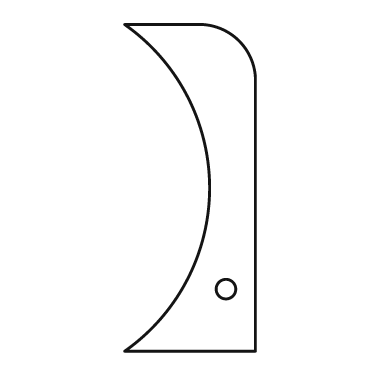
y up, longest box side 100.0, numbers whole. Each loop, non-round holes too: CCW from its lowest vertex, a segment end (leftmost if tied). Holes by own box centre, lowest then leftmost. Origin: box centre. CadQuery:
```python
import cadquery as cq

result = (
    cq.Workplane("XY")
    .moveTo(-20.0, -50.0)
    .lineTo(20.0, -50.0)
    .lineTo(20.0, 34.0)
    .threePointArc((15.0, 45.0), (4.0, 50.0))
    .lineTo(-20.0, 50.0)
    .threePointArc((6.0, 0.0), (-20.0, -50.0))
    .close()
    .moveTo(11.0, -31.0)
    .circle(3.0)
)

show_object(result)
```